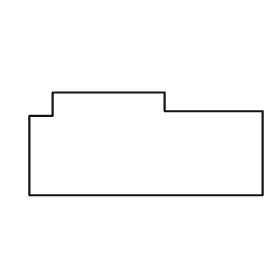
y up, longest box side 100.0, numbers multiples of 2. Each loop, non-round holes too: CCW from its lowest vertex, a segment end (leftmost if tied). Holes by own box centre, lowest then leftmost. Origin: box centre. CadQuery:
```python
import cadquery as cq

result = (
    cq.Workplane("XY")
    .moveTo(-50.0, -22.0)
    .lineTo(50.0, -22.0)
    .lineTo(50.0, 14.0)
    .lineTo(8.0, 14.0)
    .lineTo(8.0, 22.0)
    .lineTo(-40.0, 22.0)
    .lineTo(-40.0, 12.0)
    .lineTo(-50.0, 12.0)
    .close()
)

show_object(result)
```